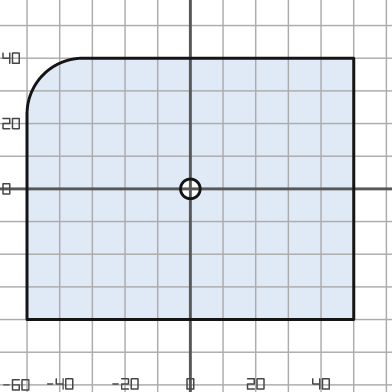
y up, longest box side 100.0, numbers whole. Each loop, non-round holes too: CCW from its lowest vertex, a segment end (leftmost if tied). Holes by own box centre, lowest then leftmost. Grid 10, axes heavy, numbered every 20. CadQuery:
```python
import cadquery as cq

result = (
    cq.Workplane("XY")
    .moveTo(-50.0, -40.0)
    .lineTo(50.0, -40.0)
    .lineTo(50.0, 40.0)
    .lineTo(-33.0, 40.0)
    .threePointArc((-45.0, 35.0), (-50.0, 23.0))
    .close()
    .moveTo(0.0, 0.0)
    .circle(3.0)
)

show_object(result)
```